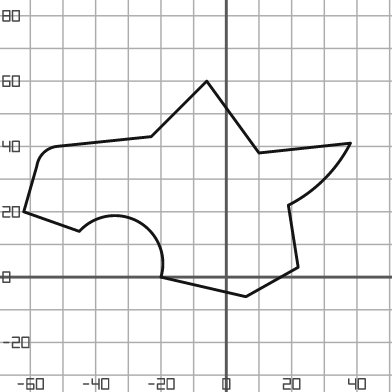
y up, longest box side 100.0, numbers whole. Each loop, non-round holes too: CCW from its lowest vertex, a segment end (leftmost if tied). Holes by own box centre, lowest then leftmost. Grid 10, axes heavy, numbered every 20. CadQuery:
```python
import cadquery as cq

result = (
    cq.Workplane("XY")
    .moveTo(6.0, -6.0)
    .lineTo(22.0, 3.0)
    .lineTo(19.0, 22.0)
    .threePointArc((30.0, 30.0), (38.0, 41.0))
    .lineTo(10.0, 38.0)
    .lineTo(-6.0, 60.0)
    .lineTo(-23.0, 43.0)
    .lineTo(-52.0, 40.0)
    .threePointArc((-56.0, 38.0), (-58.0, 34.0))
    .lineTo(-62.0, 20.0)
    .lineTo(-45.0, 14.0)
    .threePointArc((-27.0, 17.0), (-20.0, 0.0))
    .close()
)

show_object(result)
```